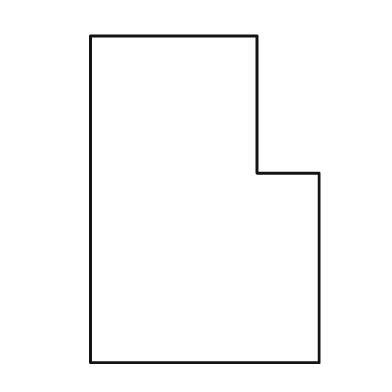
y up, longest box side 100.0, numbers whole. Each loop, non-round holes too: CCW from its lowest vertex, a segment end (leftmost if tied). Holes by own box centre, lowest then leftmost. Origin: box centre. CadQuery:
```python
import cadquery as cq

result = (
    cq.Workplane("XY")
    .moveTo(-35.0, -50.0)
    .lineTo(35.0, -50.0)
    .lineTo(35.0, 8.0)
    .lineTo(16.0, 8.0)
    .lineTo(16.0, 50.0)
    .lineTo(-35.0, 50.0)
    .close()
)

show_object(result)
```